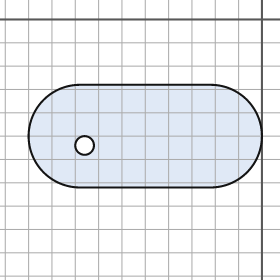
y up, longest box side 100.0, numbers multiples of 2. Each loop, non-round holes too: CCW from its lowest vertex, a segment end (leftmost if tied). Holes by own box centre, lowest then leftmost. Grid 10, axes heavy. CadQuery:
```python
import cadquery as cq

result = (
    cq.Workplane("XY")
    .moveTo(-78.0, -72.0)
    .lineTo(-22.0, -72.0)
    .threePointArc((0.0, -50.0), (-22.0, -28.0))
    .lineTo(-78.0, -28.0)
    .threePointArc((-100.0, -50.0), (-78.0, -72.0))
    .close()
    .moveTo(-76.0, -54.0)
    .circle(4.0)
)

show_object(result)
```